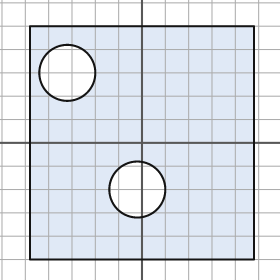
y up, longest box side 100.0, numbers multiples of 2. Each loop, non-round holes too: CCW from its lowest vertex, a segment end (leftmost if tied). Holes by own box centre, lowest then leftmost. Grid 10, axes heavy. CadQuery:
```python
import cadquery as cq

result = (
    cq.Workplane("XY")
    .moveTo(-48.0, -50.0)
    .lineTo(48.0, -50.0)
    .lineTo(48.0, 50.0)
    .lineTo(-48.0, 50.0)
    .close()
    .moveTo(-2.0, -20.0)
    .circle(12.0)
    .moveTo(-32.0, 30.0)
    .circle(12.0)
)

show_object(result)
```